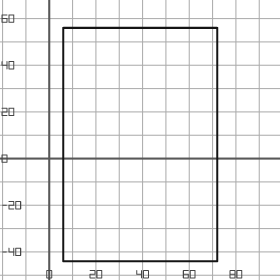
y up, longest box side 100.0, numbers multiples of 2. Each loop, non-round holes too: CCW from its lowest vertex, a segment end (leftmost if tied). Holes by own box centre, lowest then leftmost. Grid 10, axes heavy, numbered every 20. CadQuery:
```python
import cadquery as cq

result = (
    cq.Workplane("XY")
    .moveTo(6.0, -44.0)
    .lineTo(72.0, -44.0)
    .lineTo(72.0, 56.0)
    .lineTo(6.0, 56.0)
    .close()
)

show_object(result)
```